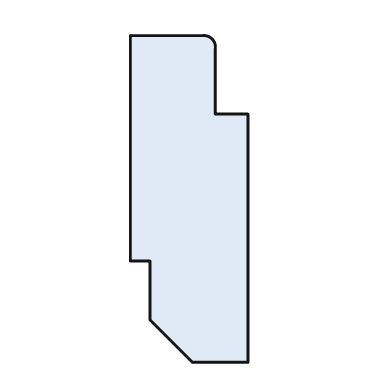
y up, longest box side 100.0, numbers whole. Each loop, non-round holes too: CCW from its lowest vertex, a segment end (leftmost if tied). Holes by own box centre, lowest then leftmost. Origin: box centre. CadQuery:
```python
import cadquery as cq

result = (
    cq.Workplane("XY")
    .moveTo(1.0, -50.0)
    .lineTo(18.0, -50.0)
    .lineTo(18.0, 26.0)
    .lineTo(8.0, 26.0)
    .lineTo(8.0, 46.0)
    .threePointArc((7.0, 49.0), (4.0, 50.0))
    .lineTo(-18.0, 50.0)
    .lineTo(-18.0, -19.0)
    .lineTo(-12.0, -19.0)
    .lineTo(-12.0, -37.0)
    .close()
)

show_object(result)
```